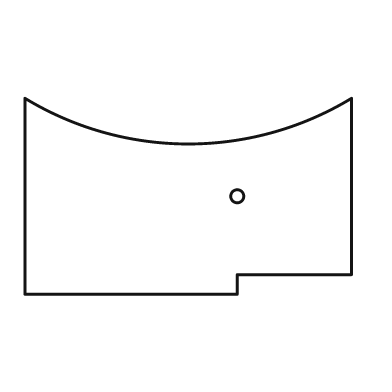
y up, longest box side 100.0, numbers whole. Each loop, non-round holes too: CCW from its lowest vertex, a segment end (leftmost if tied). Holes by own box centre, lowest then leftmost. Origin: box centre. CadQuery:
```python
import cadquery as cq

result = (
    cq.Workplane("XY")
    .moveTo(-50.0, -30.0)
    .lineTo(15.0, -30.0)
    .lineTo(15.0, -24.0)
    .lineTo(50.0, -24.0)
    .lineTo(50.0, 30.0)
    .threePointArc((0.0, 16.0), (-50.0, 30.0))
    .close()
    .moveTo(15.0, 0.0)
    .circle(2.0)
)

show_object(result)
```